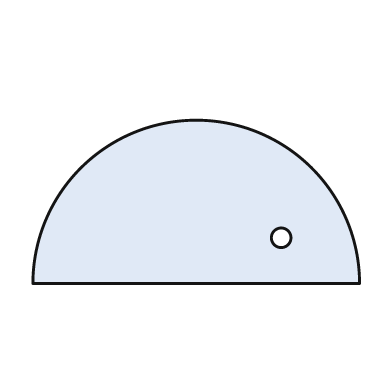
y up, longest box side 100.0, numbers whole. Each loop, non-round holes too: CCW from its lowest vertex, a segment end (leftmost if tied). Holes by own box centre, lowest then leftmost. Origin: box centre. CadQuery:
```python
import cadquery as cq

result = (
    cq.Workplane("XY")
    .moveTo(-50.0, -25.0)
    .lineTo(50.0, -25.0)
    .threePointArc((0.0, 25.0), (-50.0, -25.0))
    .close()
    .moveTo(26.0, -11.0)
    .circle(3.0)
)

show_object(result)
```